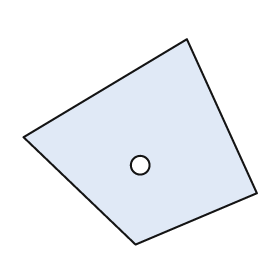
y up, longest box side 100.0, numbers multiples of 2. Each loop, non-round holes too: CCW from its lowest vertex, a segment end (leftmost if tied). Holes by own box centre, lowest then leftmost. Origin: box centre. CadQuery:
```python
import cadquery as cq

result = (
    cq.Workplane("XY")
    .moveTo(-2.0, -44.0)
    .lineTo(50.0, -22.0)
    .lineTo(20.0, 44.0)
    .lineTo(-50.0, 2.0)
    .close()
    .moveTo(0.0, -10.0)
    .circle(4.0)
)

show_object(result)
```